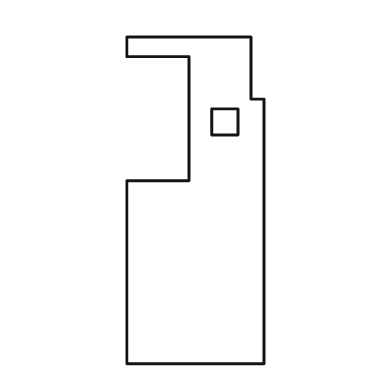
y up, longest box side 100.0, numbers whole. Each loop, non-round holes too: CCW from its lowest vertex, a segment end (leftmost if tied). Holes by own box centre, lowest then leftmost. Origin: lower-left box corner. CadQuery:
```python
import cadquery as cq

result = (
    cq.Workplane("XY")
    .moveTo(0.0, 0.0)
    .lineTo(42.0, 0.0)
    .lineTo(42.0, 81.0)
    .lineTo(38.0, 81.0)
    .lineTo(38.0, 100.0)
    .lineTo(0.0, 100.0)
    .lineTo(0.0, 94.0)
    .lineTo(19.0, 94.0)
    .lineTo(19.0, 56.0)
    .lineTo(0.0, 56.0)
    .close()
    .moveTo(26.0, 70.0)
    .lineTo(34.0, 70.0)
    .lineTo(34.0, 78.0)
    .lineTo(26.0, 78.0)
    .close()
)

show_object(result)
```